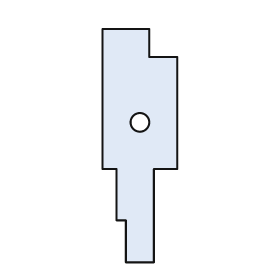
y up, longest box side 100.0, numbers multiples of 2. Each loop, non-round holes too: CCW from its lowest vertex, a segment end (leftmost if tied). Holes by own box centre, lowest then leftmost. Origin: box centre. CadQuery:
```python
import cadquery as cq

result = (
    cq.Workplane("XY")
    .moveTo(-6.0, -50.0)
    .lineTo(6.0, -50.0)
    .lineTo(6.0, -10.0)
    .lineTo(16.0, -10.0)
    .lineTo(16.0, 38.0)
    .lineTo(4.0, 38.0)
    .lineTo(4.0, 50.0)
    .lineTo(-16.0, 50.0)
    .lineTo(-16.0, -10.0)
    .lineTo(-10.0, -10.0)
    .lineTo(-10.0, -32.0)
    .lineTo(-6.0, -32.0)
    .close()
    .moveTo(0.0, 10.0)
    .circle(4.0)
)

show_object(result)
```